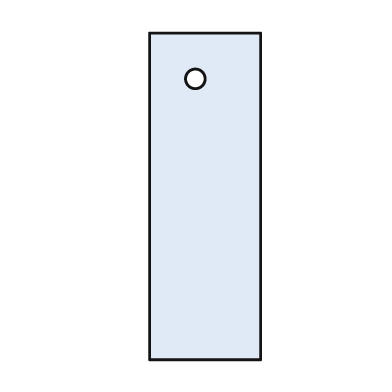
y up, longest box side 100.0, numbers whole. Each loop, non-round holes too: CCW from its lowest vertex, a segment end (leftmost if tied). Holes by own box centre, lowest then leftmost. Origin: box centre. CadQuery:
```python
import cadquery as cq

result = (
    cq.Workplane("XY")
    .moveTo(-17.0, -50.0)
    .lineTo(17.0, -50.0)
    .lineTo(17.0, 50.0)
    .lineTo(-17.0, 50.0)
    .close()
    .moveTo(-3.0, 36.0)
    .circle(3.0)
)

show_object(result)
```